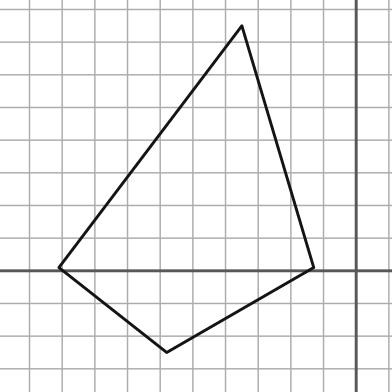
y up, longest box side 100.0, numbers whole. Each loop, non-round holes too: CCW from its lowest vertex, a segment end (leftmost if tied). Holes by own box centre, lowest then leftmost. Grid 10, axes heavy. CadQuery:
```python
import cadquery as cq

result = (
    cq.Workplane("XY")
    .moveTo(-58.0, -25.0)
    .lineTo(-13.0, 1.0)
    .lineTo(-35.0, 75.0)
    .lineTo(-91.0, 1.0)
    .close()
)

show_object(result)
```